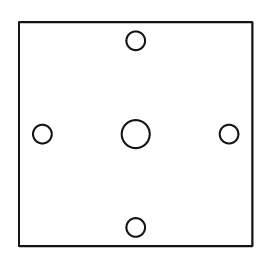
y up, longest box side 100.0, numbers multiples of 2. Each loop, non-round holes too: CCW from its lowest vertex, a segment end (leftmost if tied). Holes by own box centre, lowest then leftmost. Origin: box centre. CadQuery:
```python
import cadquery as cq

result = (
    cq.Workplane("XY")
    .moveTo(-50.0, -48.0)
    .lineTo(50.0, -48.0)
    .lineTo(50.0, 48.0)
    .lineTo(-50.0, 48.0)
    .close()
    .moveTo(0.0, -40.0)
    .circle(4.0)
    .moveTo(-40.0, 0.0)
    .circle(4.0)
    .moveTo(0.0, 0.0)
    .circle(6.0)
    .moveTo(40.0, 0.0)
    .circle(4.0)
    .moveTo(0.0, 40.0)
    .circle(4.0)
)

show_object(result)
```